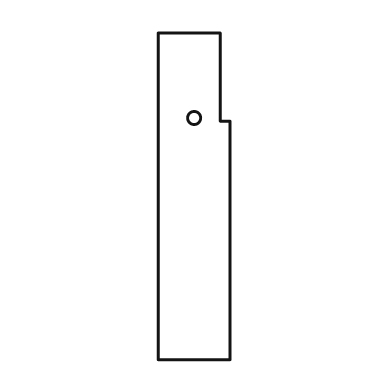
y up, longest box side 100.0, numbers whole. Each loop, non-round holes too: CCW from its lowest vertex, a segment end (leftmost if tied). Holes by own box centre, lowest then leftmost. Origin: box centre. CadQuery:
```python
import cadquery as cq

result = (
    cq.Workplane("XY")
    .moveTo(-11.0, -50.0)
    .lineTo(11.0, -50.0)
    .lineTo(11.0, 23.0)
    .lineTo(8.0, 23.0)
    .lineTo(8.0, 50.0)
    .lineTo(-11.0, 50.0)
    .close()
    .moveTo(0.0, 24.0)
    .circle(2.0)
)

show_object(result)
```